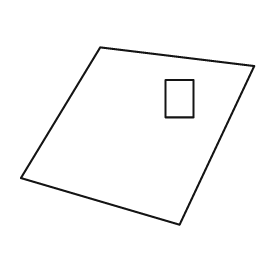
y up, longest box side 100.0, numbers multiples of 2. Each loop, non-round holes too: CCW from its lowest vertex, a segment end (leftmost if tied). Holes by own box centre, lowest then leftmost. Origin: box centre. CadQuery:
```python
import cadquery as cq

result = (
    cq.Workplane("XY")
    .moveTo(18.0, -38.0)
    .lineTo(50.0, 30.0)
    .lineTo(-16.0, 38.0)
    .lineTo(-50.0, -18.0)
    .close()
    .moveTo(12.0, 8.0)
    .lineTo(24.0, 8.0)
    .lineTo(24.0, 24.0)
    .lineTo(12.0, 24.0)
    .close()
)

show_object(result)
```